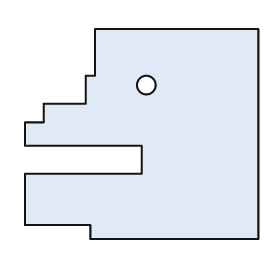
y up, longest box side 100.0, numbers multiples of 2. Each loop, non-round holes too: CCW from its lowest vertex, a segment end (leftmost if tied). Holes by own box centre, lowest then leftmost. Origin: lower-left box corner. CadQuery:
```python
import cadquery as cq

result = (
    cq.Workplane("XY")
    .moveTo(28.0, 0.0)
    .lineTo(100.0, 0.0)
    .lineTo(100.0, 90.0)
    .lineTo(30.0, 90.0)
    .lineTo(30.0, 70.0)
    .lineTo(26.0, 70.0)
    .lineTo(26.0, 58.0)
    .lineTo(8.0, 58.0)
    .lineTo(8.0, 50.0)
    .lineTo(0.0, 50.0)
    .lineTo(0.0, 40.0)
    .lineTo(50.0, 40.0)
    .lineTo(50.0, 28.0)
    .lineTo(0.0, 28.0)
    .lineTo(0.0, 6.0)
    .lineTo(28.0, 6.0)
    .close()
    .moveTo(52.0, 66.0)
    .circle(4.0)
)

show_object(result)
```